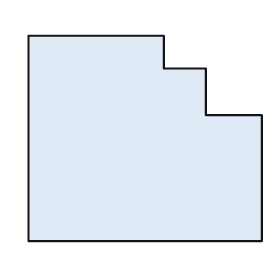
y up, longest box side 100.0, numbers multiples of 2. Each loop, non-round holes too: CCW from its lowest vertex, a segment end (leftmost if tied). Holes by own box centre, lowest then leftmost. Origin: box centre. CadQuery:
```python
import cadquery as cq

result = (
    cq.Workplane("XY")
    .moveTo(-50.0, -44.0)
    .lineTo(50.0, -44.0)
    .lineTo(50.0, 10.0)
    .lineTo(26.0, 10.0)
    .lineTo(26.0, 30.0)
    .lineTo(8.0, 30.0)
    .lineTo(8.0, 44.0)
    .lineTo(-50.0, 44.0)
    .close()
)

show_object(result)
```